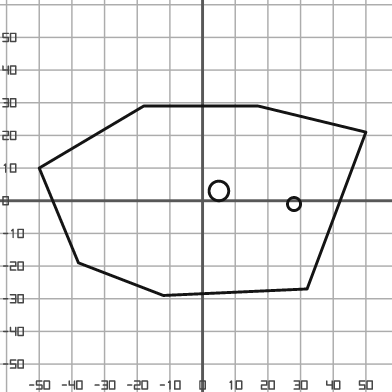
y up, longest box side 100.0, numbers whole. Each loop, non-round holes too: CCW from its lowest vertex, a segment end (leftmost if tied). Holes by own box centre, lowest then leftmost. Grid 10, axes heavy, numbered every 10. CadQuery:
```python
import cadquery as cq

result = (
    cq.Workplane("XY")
    .moveTo(-12.0, -29.0)
    .lineTo(32.0, -27.0)
    .lineTo(50.0, 21.0)
    .lineTo(17.0, 29.0)
    .lineTo(-18.0, 29.0)
    .lineTo(-50.0, 10.0)
    .lineTo(-38.0, -19.0)
    .close()
    .moveTo(28.0, -1.0)
    .circle(2.0)
    .moveTo(5.0, 3.0)
    .circle(3.0)
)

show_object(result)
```